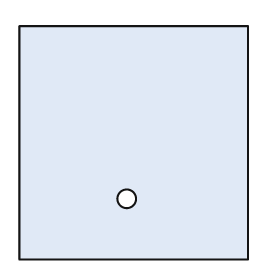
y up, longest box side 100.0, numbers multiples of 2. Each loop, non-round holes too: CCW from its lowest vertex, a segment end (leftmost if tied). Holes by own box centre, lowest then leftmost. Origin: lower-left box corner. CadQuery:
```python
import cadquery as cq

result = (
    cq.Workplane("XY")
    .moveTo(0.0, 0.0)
    .lineTo(98.0, 0.0)
    .lineTo(98.0, 100.0)
    .lineTo(0.0, 100.0)
    .close()
    .moveTo(46.0, 26.0)
    .circle(4.0)
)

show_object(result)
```